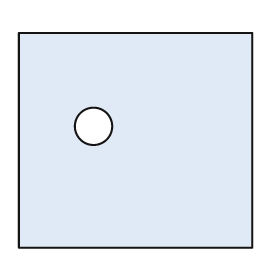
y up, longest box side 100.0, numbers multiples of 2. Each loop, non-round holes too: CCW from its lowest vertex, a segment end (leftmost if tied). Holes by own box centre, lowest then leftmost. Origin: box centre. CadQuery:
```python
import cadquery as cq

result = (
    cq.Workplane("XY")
    .moveTo(-50.0, -46.0)
    .lineTo(50.0, -46.0)
    .lineTo(50.0, 46.0)
    .lineTo(-50.0, 46.0)
    .close()
    .moveTo(-18.0, 6.0)
    .circle(8.0)
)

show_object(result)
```